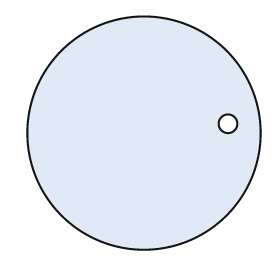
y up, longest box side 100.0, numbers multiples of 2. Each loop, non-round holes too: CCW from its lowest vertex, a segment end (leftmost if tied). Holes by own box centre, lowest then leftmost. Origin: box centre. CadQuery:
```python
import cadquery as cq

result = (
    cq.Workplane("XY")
    .moveTo(0.0, 0.0)
    .circle(50.0)
    .moveTo(36.0, 4.0)
    .circle(4.0)
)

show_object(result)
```